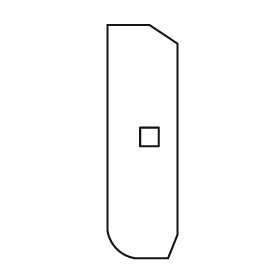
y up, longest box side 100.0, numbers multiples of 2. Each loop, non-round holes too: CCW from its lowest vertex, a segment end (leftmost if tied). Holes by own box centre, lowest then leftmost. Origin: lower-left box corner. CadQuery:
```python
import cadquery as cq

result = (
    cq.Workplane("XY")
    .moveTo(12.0, 0.0)
    .lineTo(26.0, 0.0)
    .lineTo(30.0, 10.0)
    .lineTo(30.0, 92.0)
    .lineTo(18.0, 100.0)
    .lineTo(0.0, 100.0)
    .lineTo(0.0, 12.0)
    .threePointArc((4.0, 4.0), (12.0, 0.0))
    .close()
    .moveTo(14.0, 48.0)
    .lineTo(22.0, 48.0)
    .lineTo(22.0, 56.0)
    .lineTo(14.0, 56.0)
    .close()
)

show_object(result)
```